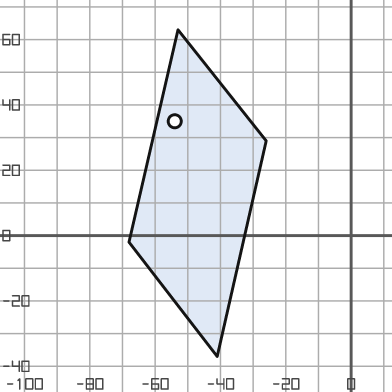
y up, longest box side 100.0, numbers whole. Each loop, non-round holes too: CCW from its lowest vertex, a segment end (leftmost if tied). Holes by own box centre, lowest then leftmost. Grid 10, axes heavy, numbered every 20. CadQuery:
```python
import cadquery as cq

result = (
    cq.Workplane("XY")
    .moveTo(-41.0, -37.0)
    .lineTo(-26.0, 29.0)
    .lineTo(-53.0, 63.0)
    .lineTo(-68.0, -2.0)
    .close()
    .moveTo(-54.0, 35.0)
    .circle(2.0)
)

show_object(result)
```